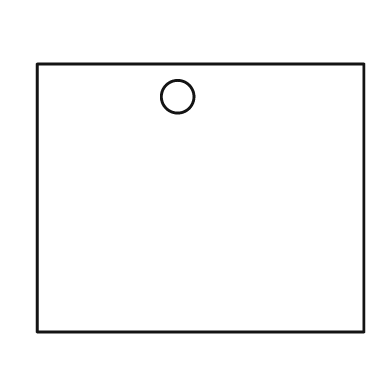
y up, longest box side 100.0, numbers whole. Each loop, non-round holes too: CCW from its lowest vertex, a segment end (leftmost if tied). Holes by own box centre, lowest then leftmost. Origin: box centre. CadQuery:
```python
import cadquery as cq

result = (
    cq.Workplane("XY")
    .moveTo(-50.0, -41.0)
    .lineTo(50.0, -41.0)
    .lineTo(50.0, 41.0)
    .lineTo(-50.0, 41.0)
    .close()
    .moveTo(-7.0, 31.0)
    .circle(5.0)
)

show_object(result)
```